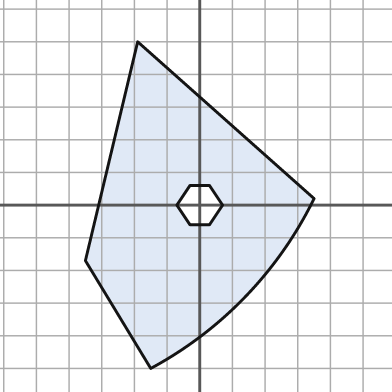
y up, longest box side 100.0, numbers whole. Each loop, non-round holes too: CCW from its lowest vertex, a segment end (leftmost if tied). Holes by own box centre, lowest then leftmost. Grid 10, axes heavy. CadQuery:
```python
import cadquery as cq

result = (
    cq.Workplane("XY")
    .moveTo(-15.0, -50.0)
    .threePointArc((14.0, -28.0), (35.0, 2.0))
    .lineTo(-19.0, 50.0)
    .lineTo(-35.0, -17.0)
    .close()
    .moveTo(-3.0, -6.0)
    .lineTo(3.0, -6.0)
    .lineTo(7.0, 0.0)
    .lineTo(3.0, 6.0)
    .lineTo(-3.0, 6.0)
    .lineTo(-7.0, 0.0)
    .close()
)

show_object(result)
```